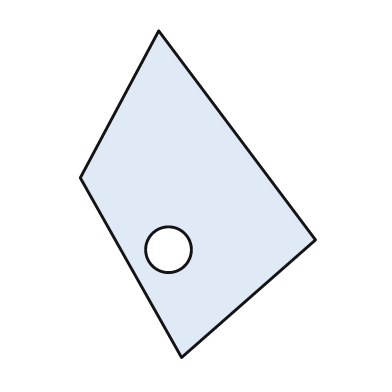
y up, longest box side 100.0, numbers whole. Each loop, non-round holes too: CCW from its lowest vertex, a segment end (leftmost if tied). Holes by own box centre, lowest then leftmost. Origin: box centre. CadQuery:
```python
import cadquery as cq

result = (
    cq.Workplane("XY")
    .moveTo(-5.0, -50.0)
    .lineTo(36.0, -14.0)
    .lineTo(-12.0, 50.0)
    .lineTo(-36.0, 5.0)
    .close()
    .moveTo(-9.0, -17.0)
    .circle(7.0)
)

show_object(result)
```